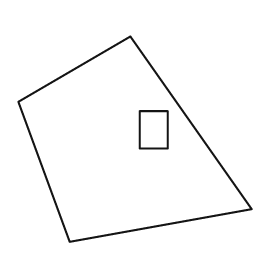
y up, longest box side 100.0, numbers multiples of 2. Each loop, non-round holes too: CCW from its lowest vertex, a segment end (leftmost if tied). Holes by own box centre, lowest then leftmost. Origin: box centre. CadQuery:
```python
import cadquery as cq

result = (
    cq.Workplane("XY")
    .moveTo(-28.0, -44.0)
    .lineTo(50.0, -30.0)
    .lineTo(-2.0, 44.0)
    .lineTo(-50.0, 16.0)
    .close()
    .moveTo(2.0, -4.0)
    .lineTo(14.0, -4.0)
    .lineTo(14.0, 12.0)
    .lineTo(2.0, 12.0)
    .close()
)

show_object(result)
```